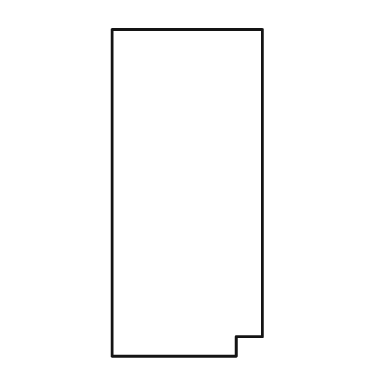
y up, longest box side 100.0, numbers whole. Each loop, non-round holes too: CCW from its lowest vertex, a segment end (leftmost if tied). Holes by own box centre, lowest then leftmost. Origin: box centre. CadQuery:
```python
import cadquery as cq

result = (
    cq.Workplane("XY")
    .moveTo(-23.0, -50.0)
    .lineTo(15.0, -50.0)
    .lineTo(15.0, -44.0)
    .lineTo(23.0, -44.0)
    .lineTo(23.0, 50.0)
    .lineTo(-23.0, 50.0)
    .close()
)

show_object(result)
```